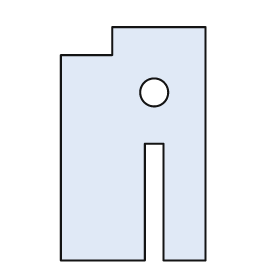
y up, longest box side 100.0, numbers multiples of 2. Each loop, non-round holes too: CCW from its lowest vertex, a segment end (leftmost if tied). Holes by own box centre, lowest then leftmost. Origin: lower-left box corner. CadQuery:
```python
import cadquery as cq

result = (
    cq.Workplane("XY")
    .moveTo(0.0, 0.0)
    .lineTo(36.0, 0.0)
    .lineTo(36.0, 50.0)
    .lineTo(44.0, 50.0)
    .lineTo(44.0, 0.0)
    .lineTo(62.0, 0.0)
    .lineTo(62.0, 100.0)
    .lineTo(22.0, 100.0)
    .lineTo(22.0, 88.0)
    .lineTo(0.0, 88.0)
    .close()
    .moveTo(40.0, 72.0)
    .circle(6.0)
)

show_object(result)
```